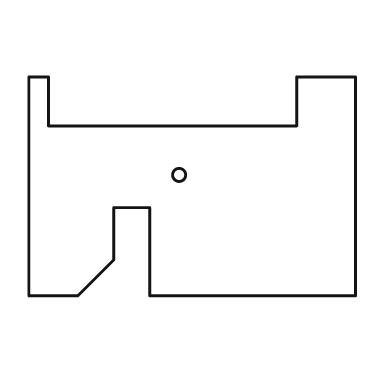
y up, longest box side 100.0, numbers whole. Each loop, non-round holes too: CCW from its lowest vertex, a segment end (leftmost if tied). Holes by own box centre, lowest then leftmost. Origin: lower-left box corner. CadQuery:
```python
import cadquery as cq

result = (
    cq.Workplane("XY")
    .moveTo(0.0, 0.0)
    .lineTo(15.0, 0.0)
    .lineTo(26.0, 11.0)
    .lineTo(26.0, 27.0)
    .lineTo(37.0, 27.0)
    .lineTo(37.0, 0.0)
    .lineTo(100.0, 0.0)
    .lineTo(100.0, 67.0)
    .lineTo(82.0, 67.0)
    .lineTo(82.0, 52.0)
    .lineTo(6.0, 52.0)
    .lineTo(6.0, 67.0)
    .lineTo(0.0, 67.0)
    .close()
    .moveTo(46.0, 37.0)
    .circle(2.0)
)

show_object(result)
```